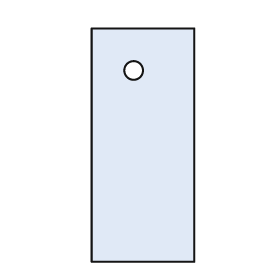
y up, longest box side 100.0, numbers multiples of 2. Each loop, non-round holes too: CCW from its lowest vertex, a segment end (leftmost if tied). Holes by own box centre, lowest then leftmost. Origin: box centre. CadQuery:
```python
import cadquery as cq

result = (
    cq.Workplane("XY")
    .moveTo(-22.0, -50.0)
    .lineTo(22.0, -50.0)
    .lineTo(22.0, 50.0)
    .lineTo(-22.0, 50.0)
    .close()
    .moveTo(-4.0, 32.0)
    .circle(4.0)
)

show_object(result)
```